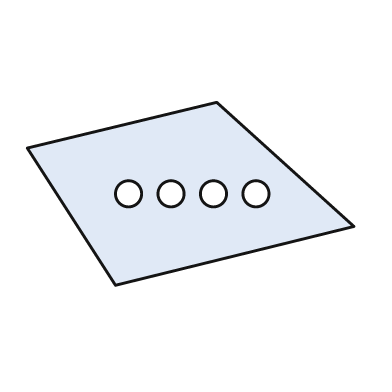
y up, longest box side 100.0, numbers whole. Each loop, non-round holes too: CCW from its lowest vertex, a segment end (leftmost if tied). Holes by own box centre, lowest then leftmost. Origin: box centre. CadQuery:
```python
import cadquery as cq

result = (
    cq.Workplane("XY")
    .moveTo(-23.0, -28.0)
    .lineTo(50.0, -10.0)
    .lineTo(8.0, 28.0)
    .lineTo(-50.0, 14.0)
    .close()
    .moveTo(-19.0, 0.0)
    .circle(4.0)
    .moveTo(-6.0, 0.0)
    .circle(4.0)
    .moveTo(7.0, 0.0)
    .circle(4.0)
    .moveTo(20.0, 0.0)
    .circle(4.0)
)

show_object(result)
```